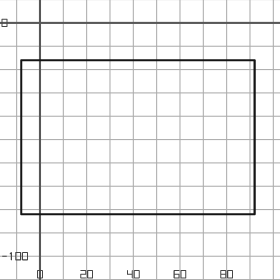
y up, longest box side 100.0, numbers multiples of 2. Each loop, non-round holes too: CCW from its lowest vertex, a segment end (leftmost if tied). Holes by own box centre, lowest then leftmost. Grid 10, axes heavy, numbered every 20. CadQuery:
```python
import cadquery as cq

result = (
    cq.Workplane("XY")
    .moveTo(-8.0, -82.0)
    .lineTo(92.0, -82.0)
    .lineTo(92.0, -16.0)
    .lineTo(-8.0, -16.0)
    .close()
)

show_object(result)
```